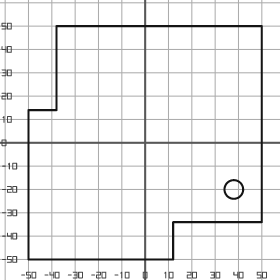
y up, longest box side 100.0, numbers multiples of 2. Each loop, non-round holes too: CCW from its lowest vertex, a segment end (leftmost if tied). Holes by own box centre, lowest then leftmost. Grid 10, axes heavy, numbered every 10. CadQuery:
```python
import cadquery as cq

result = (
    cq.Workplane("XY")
    .moveTo(-50.0, -50.0)
    .lineTo(12.0, -50.0)
    .lineTo(12.0, -34.0)
    .lineTo(50.0, -34.0)
    .lineTo(50.0, 50.0)
    .lineTo(-38.0, 50.0)
    .lineTo(-38.0, 14.0)
    .lineTo(-50.0, 14.0)
    .close()
    .moveTo(38.0, -20.0)
    .circle(4.0)
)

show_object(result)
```